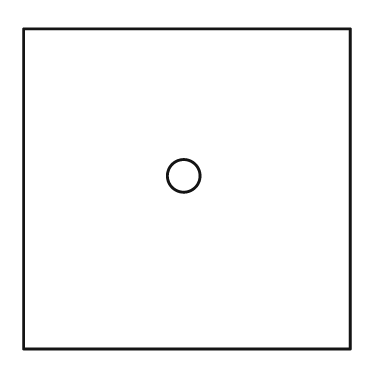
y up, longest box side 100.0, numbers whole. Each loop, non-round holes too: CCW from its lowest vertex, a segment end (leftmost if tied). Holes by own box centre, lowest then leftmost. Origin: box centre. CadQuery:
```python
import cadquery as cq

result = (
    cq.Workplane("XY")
    .moveTo(-50.0, -49.0)
    .lineTo(50.0, -49.0)
    .lineTo(50.0, 49.0)
    .lineTo(-50.0, 49.0)
    .close()
    .moveTo(-1.0, 4.0)
    .circle(5.0)
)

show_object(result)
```